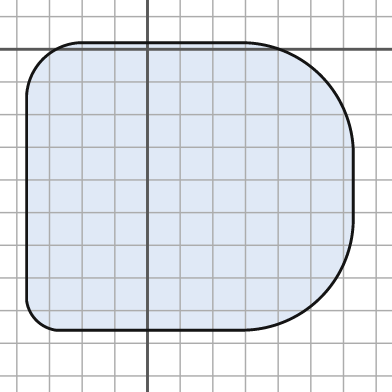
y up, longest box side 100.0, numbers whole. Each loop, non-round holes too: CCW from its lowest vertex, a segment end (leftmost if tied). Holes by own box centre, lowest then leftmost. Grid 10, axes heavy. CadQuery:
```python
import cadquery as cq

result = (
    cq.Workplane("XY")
    .moveTo(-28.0, -86.0)
    .lineTo(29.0, -86.0)
    .threePointArc((53.0, -76.0), (63.0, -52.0))
    .lineTo(63.0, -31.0)
    .threePointArc((53.0, -8.0), (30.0, 2.0))
    .lineTo(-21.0, 2.0)
    .threePointArc((-32.0, -3.0), (-37.0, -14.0))
    .lineTo(-37.0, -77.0)
    .threePointArc((-34.0, -83.0), (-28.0, -86.0))
    .close()
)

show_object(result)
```